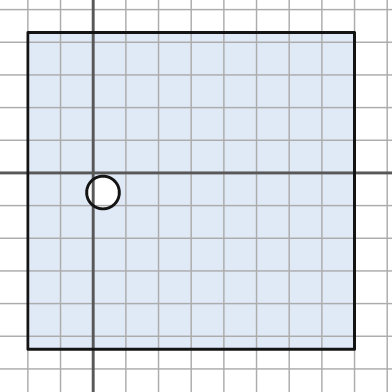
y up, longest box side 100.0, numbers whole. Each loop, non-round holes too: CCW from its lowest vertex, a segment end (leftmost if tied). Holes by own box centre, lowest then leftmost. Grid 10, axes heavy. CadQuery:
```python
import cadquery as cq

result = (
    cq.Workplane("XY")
    .moveTo(-20.0, -54.0)
    .lineTo(80.0, -54.0)
    .lineTo(80.0, 43.0)
    .lineTo(-20.0, 43.0)
    .close()
    .moveTo(3.0, -6.0)
    .circle(5.0)
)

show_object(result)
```